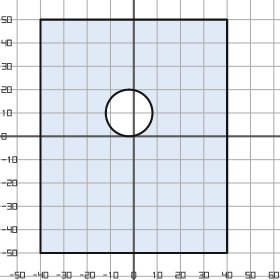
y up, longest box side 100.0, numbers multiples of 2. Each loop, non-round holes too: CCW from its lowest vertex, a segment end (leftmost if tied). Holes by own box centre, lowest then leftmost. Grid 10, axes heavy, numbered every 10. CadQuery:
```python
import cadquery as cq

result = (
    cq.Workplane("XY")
    .moveTo(-40.0, -50.0)
    .lineTo(40.0, -50.0)
    .lineTo(40.0, 50.0)
    .lineTo(-40.0, 50.0)
    .close()
    .moveTo(-2.0, 10.0)
    .circle(10.0)
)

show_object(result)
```